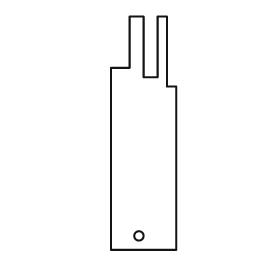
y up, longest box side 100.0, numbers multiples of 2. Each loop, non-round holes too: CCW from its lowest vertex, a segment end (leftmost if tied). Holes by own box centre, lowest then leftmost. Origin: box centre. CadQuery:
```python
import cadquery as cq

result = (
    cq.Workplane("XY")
    .moveTo(-14.0, -50.0)
    .lineTo(14.0, -50.0)
    .lineTo(14.0, 20.0)
    .lineTo(10.0, 20.0)
    .lineTo(10.0, 50.0)
    .lineTo(6.0, 50.0)
    .lineTo(6.0, 24.0)
    .lineTo(0.0, 24.0)
    .lineTo(0.0, 50.0)
    .lineTo(-6.0, 50.0)
    .lineTo(-6.0, 28.0)
    .lineTo(-14.0, 28.0)
    .close()
    .moveTo(-2.0, -44.0)
    .circle(2.0)
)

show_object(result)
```